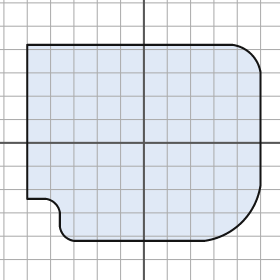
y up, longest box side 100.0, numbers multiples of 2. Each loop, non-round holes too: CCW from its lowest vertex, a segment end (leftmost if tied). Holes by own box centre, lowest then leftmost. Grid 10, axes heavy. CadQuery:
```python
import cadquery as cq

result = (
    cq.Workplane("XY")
    .moveTo(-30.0, -42.0)
    .lineTo(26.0, -42.0)
    .threePointArc((42.0, -34.0), (50.0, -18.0))
    .lineTo(50.0, 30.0)
    .threePointArc((46.0, 38.0), (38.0, 42.0))
    .lineTo(-50.0, 42.0)
    .lineTo(-50.0, -24.0)
    .lineTo(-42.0, -24.0)
    .threePointArc((-38.0, -26.0), (-36.0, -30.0))
    .lineTo(-36.0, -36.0)
    .threePointArc((-34.0, -40.0), (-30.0, -42.0))
    .close()
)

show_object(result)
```